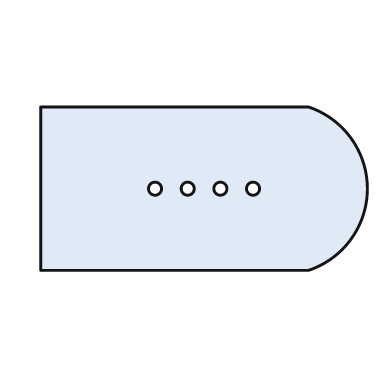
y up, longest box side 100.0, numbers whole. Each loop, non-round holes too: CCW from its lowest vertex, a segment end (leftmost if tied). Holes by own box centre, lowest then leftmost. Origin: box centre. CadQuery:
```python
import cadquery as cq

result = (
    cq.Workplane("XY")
    .moveTo(-50.0, -25.0)
    .lineTo(32.0, -25.0)
    .threePointArc((50.0, 0.0), (32.0, 25.0))
    .lineTo(-50.0, 25.0)
    .close()
    .moveTo(-15.0, 0.0)
    .circle(2.0)
    .moveTo(-5.0, 0.0)
    .circle(2.0)
    .moveTo(5.0, 0.0)
    .circle(2.0)
    .moveTo(15.0, 0.0)
    .circle(2.0)
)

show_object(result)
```